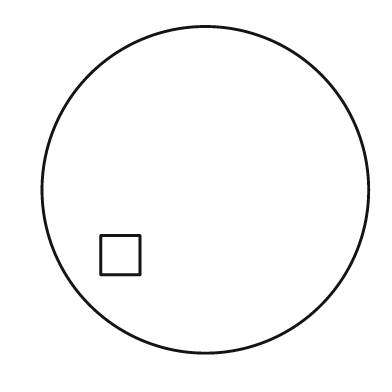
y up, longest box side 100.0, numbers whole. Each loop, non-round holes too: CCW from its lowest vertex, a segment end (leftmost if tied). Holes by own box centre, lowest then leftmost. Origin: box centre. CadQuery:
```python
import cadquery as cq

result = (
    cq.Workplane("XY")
    .moveTo(0.0, 0.0)
    .circle(50.0)
    .moveTo(-32.0, -26.0)
    .lineTo(-20.0, -26.0)
    .lineTo(-20.0, -14.0)
    .lineTo(-32.0, -14.0)
    .close()
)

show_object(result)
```